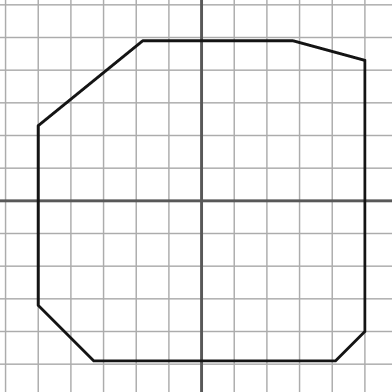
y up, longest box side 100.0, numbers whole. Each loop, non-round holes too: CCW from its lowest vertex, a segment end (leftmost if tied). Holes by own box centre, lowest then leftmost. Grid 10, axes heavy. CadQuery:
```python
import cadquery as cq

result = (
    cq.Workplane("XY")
    .moveTo(-33.0, -49.0)
    .lineTo(41.0, -49.0)
    .lineTo(50.0, -40.0)
    .lineTo(50.0, 43.0)
    .lineTo(28.0, 49.0)
    .lineTo(-18.0, 49.0)
    .lineTo(-50.0, 23.0)
    .lineTo(-50.0, -32.0)
    .close()
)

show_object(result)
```